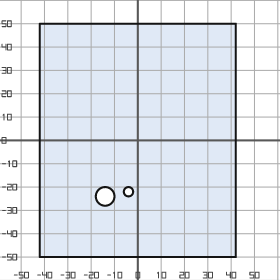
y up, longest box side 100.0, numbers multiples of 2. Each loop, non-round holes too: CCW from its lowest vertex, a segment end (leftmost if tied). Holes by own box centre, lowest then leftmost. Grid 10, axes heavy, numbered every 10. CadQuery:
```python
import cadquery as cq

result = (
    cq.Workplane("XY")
    .moveTo(-42.0, -50.0)
    .lineTo(42.0, -50.0)
    .lineTo(42.0, 50.0)
    .lineTo(-42.0, 50.0)
    .close()
    .moveTo(-14.0, -24.0)
    .circle(4.0)
    .moveTo(-4.0, -22.0)
    .circle(2.0)
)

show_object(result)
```